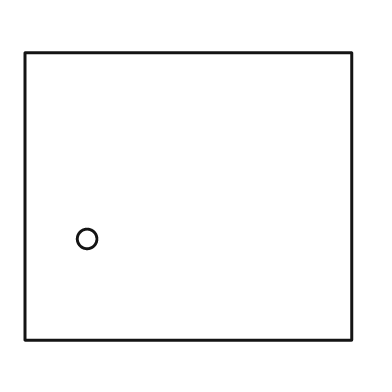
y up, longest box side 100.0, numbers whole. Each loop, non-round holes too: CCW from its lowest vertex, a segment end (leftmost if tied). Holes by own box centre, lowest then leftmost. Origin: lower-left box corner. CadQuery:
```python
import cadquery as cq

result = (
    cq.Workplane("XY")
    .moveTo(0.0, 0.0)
    .lineTo(100.0, 0.0)
    .lineTo(100.0, 88.0)
    .lineTo(0.0, 88.0)
    .close()
    .moveTo(19.0, 31.0)
    .circle(3.0)
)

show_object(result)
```